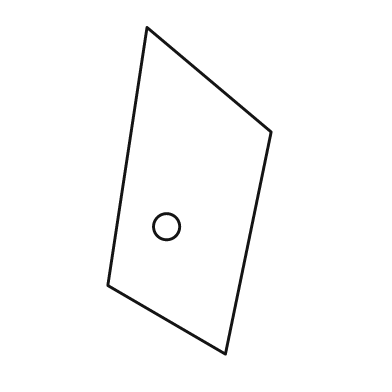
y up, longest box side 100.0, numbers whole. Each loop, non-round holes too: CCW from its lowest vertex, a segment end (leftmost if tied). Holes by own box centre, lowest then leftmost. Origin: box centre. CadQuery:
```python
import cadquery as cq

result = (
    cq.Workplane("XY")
    .moveTo(11.0, -50.0)
    .lineTo(25.0, 18.0)
    .lineTo(-13.0, 50.0)
    .lineTo(-25.0, -29.0)
    .close()
    .moveTo(-7.0, -11.0)
    .circle(4.0)
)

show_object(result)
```